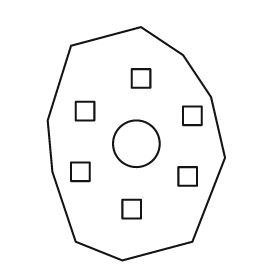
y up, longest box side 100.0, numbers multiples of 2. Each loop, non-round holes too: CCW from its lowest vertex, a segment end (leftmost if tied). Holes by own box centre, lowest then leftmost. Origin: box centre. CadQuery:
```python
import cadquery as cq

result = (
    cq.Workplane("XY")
    .moveTo(-6.0, -50.0)
    .lineTo(24.0, -42.0)
    .lineTo(38.0, -6.0)
    .lineTo(32.0, 20.0)
    .lineTo(20.0, 38.0)
    .lineTo(2.0, 50.0)
    .lineTo(-28.0, 42.0)
    .lineTo(-38.0, 10.0)
    .lineTo(-36.0, -12.0)
    .lineTo(-26.0, -42.0)
    .close()
    .moveTo(-6.0, -32.0)
    .lineTo(2.0, -32.0)
    .lineTo(2.0, -24.0)
    .lineTo(-6.0, -24.0)
    .close()
    .moveTo(18.0, -18.0)
    .lineTo(26.0, -18.0)
    .lineTo(26.0, -10.0)
    .lineTo(18.0, -10.0)
    .close()
    .moveTo(-28.0, -16.0)
    .lineTo(-20.0, -16.0)
    .lineTo(-20.0, -8.0)
    .lineTo(-28.0, -8.0)
    .close()
    .moveTo(0.0, 0.0)
    .circle(10.0)
    .moveTo(20.0, 8.0)
    .lineTo(28.0, 8.0)
    .lineTo(28.0, 16.0)
    .lineTo(20.0, 16.0)
    .close()
    .moveTo(-26.0, 10.0)
    .lineTo(-18.0, 10.0)
    .lineTo(-18.0, 18.0)
    .lineTo(-26.0, 18.0)
    .close()
    .moveTo(-2.0, 24.0)
    .lineTo(6.0, 24.0)
    .lineTo(6.0, 32.0)
    .lineTo(-2.0, 32.0)
    .close()
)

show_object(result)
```